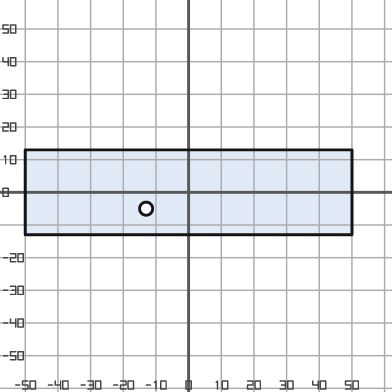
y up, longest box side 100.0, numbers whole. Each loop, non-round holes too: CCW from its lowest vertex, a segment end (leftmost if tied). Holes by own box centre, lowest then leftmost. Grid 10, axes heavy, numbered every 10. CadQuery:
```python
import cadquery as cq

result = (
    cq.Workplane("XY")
    .moveTo(-50.0, -13.0)
    .lineTo(50.0, -13.0)
    .lineTo(50.0, 13.0)
    .lineTo(-50.0, 13.0)
    .close()
    .moveTo(-13.0, -5.0)
    .circle(2.0)
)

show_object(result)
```